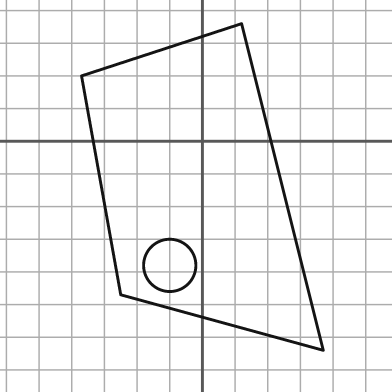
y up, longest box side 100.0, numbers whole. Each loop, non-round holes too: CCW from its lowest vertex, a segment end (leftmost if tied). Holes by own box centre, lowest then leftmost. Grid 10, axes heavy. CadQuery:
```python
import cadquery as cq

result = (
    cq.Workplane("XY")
    .moveTo(37.0, -64.0)
    .lineTo(12.0, 36.0)
    .lineTo(-37.0, 20.0)
    .lineTo(-25.0, -47.0)
    .close()
    .moveTo(-10.0, -38.0)
    .circle(8.0)
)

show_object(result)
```